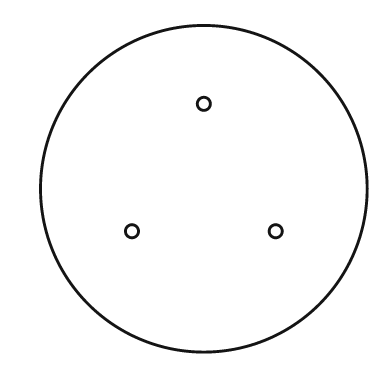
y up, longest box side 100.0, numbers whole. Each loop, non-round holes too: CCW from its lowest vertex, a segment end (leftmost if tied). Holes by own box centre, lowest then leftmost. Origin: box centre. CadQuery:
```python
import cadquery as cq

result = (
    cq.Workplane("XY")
    .moveTo(0.0, 0.0)
    .circle(50.0)
    .moveTo(-22.0, -13.0)
    .circle(2.0)
    .moveTo(22.0, -13.0)
    .circle(2.0)
    .moveTo(0.0, 26.0)
    .circle(2.0)
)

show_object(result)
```